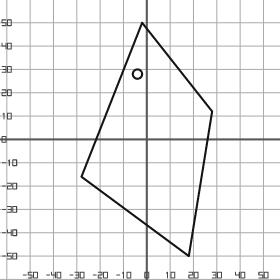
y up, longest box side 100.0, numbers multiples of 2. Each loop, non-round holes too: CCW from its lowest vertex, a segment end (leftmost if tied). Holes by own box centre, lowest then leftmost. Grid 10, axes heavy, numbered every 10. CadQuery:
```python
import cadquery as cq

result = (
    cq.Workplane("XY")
    .moveTo(18.0, -50.0)
    .lineTo(28.0, 12.0)
    .lineTo(-2.0, 50.0)
    .lineTo(-28.0, -16.0)
    .close()
    .moveTo(-4.0, 28.0)
    .circle(2.0)
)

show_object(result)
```